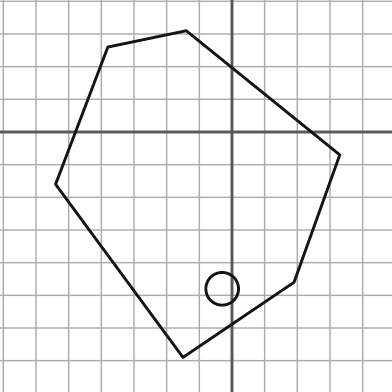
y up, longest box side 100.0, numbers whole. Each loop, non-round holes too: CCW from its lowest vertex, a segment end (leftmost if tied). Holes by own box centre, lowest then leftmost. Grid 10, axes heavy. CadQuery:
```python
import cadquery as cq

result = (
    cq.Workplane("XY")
    .moveTo(-15.0, -69.0)
    .lineTo(19.0, -46.0)
    .lineTo(33.0, -7.0)
    .lineTo(-14.0, 31.0)
    .lineTo(-38.0, 26.0)
    .lineTo(-54.0, -16.0)
    .close()
    .moveTo(-3.0, -48.0)
    .circle(5.0)
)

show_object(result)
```